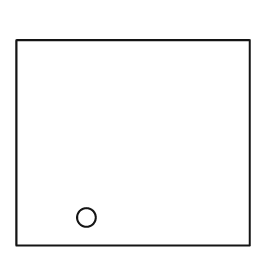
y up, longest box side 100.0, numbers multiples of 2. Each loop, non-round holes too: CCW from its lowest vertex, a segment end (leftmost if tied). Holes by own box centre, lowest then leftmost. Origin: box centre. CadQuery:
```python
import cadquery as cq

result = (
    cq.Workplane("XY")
    .moveTo(-50.0, -44.0)
    .lineTo(50.0, -44.0)
    .lineTo(50.0, 44.0)
    .lineTo(-50.0, 44.0)
    .close()
    .moveTo(-20.0, -32.0)
    .circle(4.0)
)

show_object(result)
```